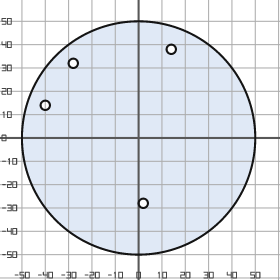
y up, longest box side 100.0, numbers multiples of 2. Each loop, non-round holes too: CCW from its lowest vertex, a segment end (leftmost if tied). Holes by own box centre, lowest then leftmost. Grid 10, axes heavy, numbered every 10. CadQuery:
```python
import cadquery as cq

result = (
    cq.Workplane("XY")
    .moveTo(0.0, 0.0)
    .circle(50.0)
    .moveTo(2.0, -28.0)
    .circle(2.0)
    .moveTo(-40.0, 14.0)
    .circle(2.0)
    .moveTo(-28.0, 32.0)
    .circle(2.0)
    .moveTo(14.0, 38.0)
    .circle(2.0)
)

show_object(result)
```